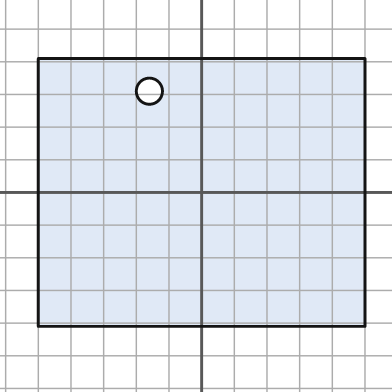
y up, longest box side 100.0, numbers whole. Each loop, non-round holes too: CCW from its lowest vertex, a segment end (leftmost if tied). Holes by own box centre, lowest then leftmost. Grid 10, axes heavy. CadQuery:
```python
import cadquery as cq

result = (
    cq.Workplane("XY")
    .moveTo(-50.0, -41.0)
    .lineTo(50.0, -41.0)
    .lineTo(50.0, 41.0)
    .lineTo(-50.0, 41.0)
    .close()
    .moveTo(-16.0, 31.0)
    .circle(4.0)
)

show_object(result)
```